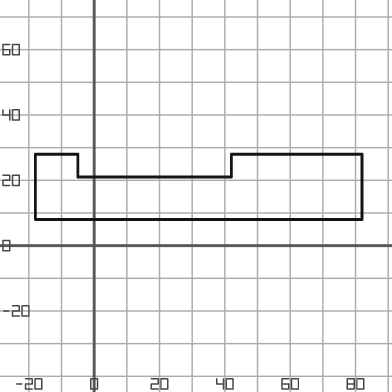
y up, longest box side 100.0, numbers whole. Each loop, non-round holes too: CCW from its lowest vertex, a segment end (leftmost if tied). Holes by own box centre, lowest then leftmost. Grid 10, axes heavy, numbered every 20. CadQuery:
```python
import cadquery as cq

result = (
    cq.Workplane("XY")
    .moveTo(-18.0, 8.0)
    .lineTo(82.0, 8.0)
    .lineTo(82.0, 28.0)
    .lineTo(42.0, 28.0)
    .lineTo(42.0, 21.0)
    .lineTo(-5.0, 21.0)
    .lineTo(-5.0, 28.0)
    .lineTo(-18.0, 28.0)
    .close()
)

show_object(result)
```